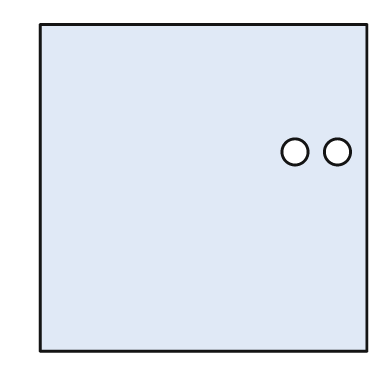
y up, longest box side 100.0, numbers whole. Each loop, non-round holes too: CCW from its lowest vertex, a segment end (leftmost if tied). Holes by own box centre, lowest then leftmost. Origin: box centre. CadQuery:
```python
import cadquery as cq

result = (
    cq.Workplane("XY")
    .moveTo(-50.0, -50.0)
    .lineTo(50.0, -50.0)
    .lineTo(50.0, 50.0)
    .lineTo(-50.0, 50.0)
    .close()
    .moveTo(28.0, 11.0)
    .circle(4.0)
    .moveTo(41.0, 11.0)
    .circle(4.0)
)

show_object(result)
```